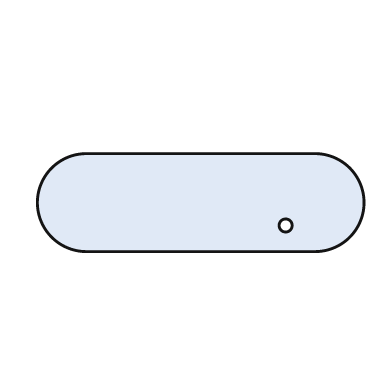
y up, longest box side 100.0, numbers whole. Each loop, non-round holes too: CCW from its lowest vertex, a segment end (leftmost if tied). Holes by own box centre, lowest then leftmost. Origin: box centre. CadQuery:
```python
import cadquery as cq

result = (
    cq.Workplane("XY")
    .moveTo(-35.0, -15.0)
    .lineTo(35.0, -15.0)
    .threePointArc((50.0, 0.0), (35.0, 15.0))
    .lineTo(-35.0, 15.0)
    .threePointArc((-50.0, 0.0), (-35.0, -15.0))
    .close()
    .moveTo(26.0, -7.0)
    .circle(2.0)
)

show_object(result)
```